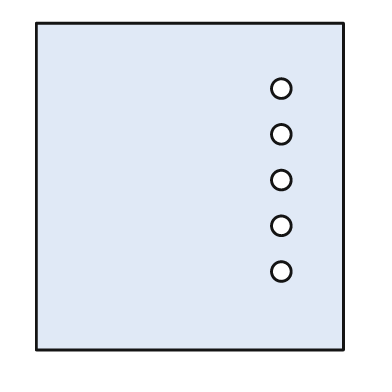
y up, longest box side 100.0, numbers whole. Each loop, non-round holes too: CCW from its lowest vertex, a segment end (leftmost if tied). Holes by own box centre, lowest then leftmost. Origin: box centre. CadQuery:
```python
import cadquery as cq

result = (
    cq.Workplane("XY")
    .moveTo(-47.0, -50.0)
    .lineTo(47.0, -50.0)
    .lineTo(47.0, 50.0)
    .lineTo(-47.0, 50.0)
    .close()
    .moveTo(28.0, -26.0)
    .circle(3.0)
    .moveTo(28.0, -12.0)
    .circle(3.0)
    .moveTo(28.0, 2.0)
    .circle(3.0)
    .moveTo(28.0, 16.0)
    .circle(3.0)
    .moveTo(28.0, 30.0)
    .circle(3.0)
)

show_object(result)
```